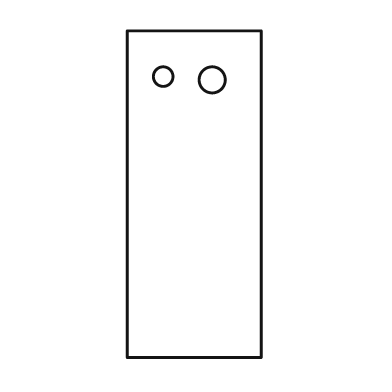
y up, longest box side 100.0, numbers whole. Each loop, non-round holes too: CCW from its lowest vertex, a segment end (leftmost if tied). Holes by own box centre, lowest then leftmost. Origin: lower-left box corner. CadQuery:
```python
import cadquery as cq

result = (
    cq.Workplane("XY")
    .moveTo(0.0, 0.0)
    .lineTo(41.0, 0.0)
    .lineTo(41.0, 100.0)
    .lineTo(0.0, 100.0)
    .close()
    .moveTo(26.0, 85.0)
    .circle(4.0)
    .moveTo(11.0, 86.0)
    .circle(3.0)
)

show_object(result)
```